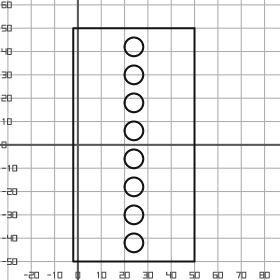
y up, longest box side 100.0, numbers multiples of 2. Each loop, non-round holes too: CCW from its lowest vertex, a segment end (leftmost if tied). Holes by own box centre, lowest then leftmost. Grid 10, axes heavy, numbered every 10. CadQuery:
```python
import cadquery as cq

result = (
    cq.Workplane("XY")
    .moveTo(-2.0, -50.0)
    .lineTo(50.0, -50.0)
    .lineTo(50.0, 50.0)
    .lineTo(-2.0, 50.0)
    .close()
    .moveTo(24.0, -42.0)
    .circle(4.0)
    .moveTo(24.0, -30.0)
    .circle(4.0)
    .moveTo(24.0, -18.0)
    .circle(4.0)
    .moveTo(24.0, -6.0)
    .circle(4.0)
    .moveTo(24.0, 6.0)
    .circle(4.0)
    .moveTo(24.0, 18.0)
    .circle(4.0)
    .moveTo(24.0, 30.0)
    .circle(4.0)
    .moveTo(24.0, 42.0)
    .circle(4.0)
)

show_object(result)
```